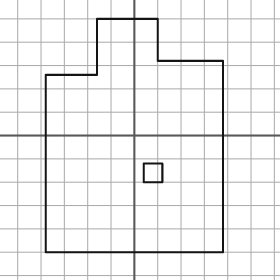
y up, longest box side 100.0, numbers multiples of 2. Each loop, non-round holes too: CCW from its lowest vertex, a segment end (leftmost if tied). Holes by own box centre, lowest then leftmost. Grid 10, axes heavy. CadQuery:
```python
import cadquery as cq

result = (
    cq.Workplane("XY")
    .moveTo(-38.0, -50.0)
    .lineTo(38.0, -50.0)
    .lineTo(38.0, 32.0)
    .lineTo(10.0, 32.0)
    .lineTo(10.0, 50.0)
    .lineTo(-16.0, 50.0)
    .lineTo(-16.0, 26.0)
    .lineTo(-38.0, 26.0)
    .close()
    .moveTo(4.0, -20.0)
    .lineTo(12.0, -20.0)
    .lineTo(12.0, -12.0)
    .lineTo(4.0, -12.0)
    .close()
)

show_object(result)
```